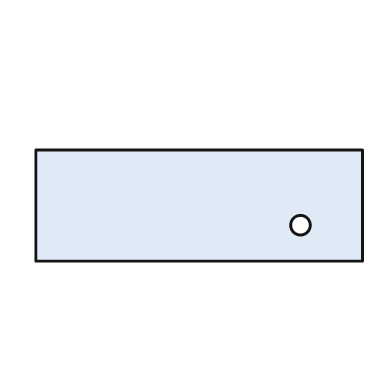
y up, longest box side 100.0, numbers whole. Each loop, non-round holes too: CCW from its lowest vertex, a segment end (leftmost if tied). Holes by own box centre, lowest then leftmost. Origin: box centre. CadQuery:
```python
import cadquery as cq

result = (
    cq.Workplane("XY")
    .moveTo(-50.0, -17.0)
    .lineTo(50.0, -17.0)
    .lineTo(50.0, 17.0)
    .lineTo(-50.0, 17.0)
    .close()
    .moveTo(31.0, -6.0)
    .circle(3.0)
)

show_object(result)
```